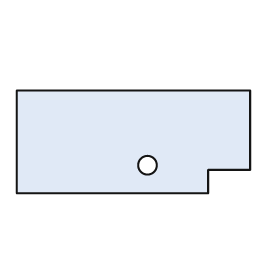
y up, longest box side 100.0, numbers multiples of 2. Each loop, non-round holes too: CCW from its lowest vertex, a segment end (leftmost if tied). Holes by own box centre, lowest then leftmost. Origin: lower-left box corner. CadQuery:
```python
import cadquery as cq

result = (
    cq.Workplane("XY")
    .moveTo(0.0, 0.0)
    .lineTo(82.0, 0.0)
    .lineTo(82.0, 10.0)
    .lineTo(100.0, 10.0)
    .lineTo(100.0, 44.0)
    .lineTo(0.0, 44.0)
    .close()
    .moveTo(56.0, 12.0)
    .circle(4.0)
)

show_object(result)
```